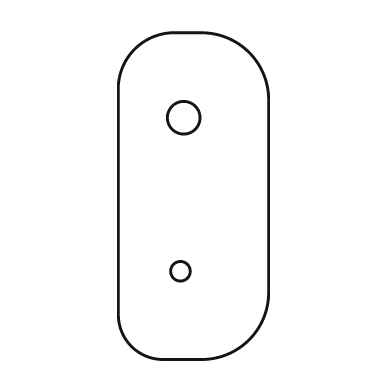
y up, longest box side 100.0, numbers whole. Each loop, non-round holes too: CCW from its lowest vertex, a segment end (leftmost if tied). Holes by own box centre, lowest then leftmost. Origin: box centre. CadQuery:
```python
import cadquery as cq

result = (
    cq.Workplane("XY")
    .moveTo(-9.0, -50.0)
    .lineTo(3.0, -50.0)
    .threePointArc((17.0, -44.0), (23.0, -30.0))
    .lineTo(23.0, 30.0)
    .threePointArc((17.0, 44.0), (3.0, 50.0))
    .lineTo(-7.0, 50.0)
    .threePointArc((-18.0, 45.0), (-23.0, 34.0))
    .lineTo(-23.0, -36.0)
    .threePointArc((-19.0, -46.0), (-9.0, -50.0))
    .close()
    .moveTo(-4.0, -23.0)
    .circle(3.0)
    .moveTo(-3.0, 24.0)
    .circle(5.0)
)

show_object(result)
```